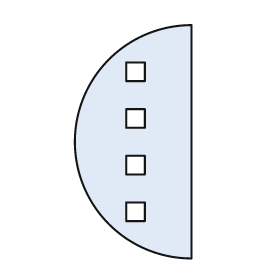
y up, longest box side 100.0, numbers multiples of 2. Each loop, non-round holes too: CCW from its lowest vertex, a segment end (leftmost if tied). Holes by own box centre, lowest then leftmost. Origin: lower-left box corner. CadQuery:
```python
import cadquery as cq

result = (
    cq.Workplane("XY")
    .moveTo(50.0, 0.0)
    .lineTo(50.0, 100.0)
    .threePointArc((0.0, 50.0), (50.0, 0.0))
    .close()
    .moveTo(22.0, 16.0)
    .lineTo(30.0, 16.0)
    .lineTo(30.0, 24.0)
    .lineTo(22.0, 24.0)
    .close()
    .moveTo(22.0, 36.0)
    .lineTo(30.0, 36.0)
    .lineTo(30.0, 44.0)
    .lineTo(22.0, 44.0)
    .close()
    .moveTo(22.0, 56.0)
    .lineTo(30.0, 56.0)
    .lineTo(30.0, 64.0)
    .lineTo(22.0, 64.0)
    .close()
    .moveTo(22.0, 76.0)
    .lineTo(30.0, 76.0)
    .lineTo(30.0, 84.0)
    .lineTo(22.0, 84.0)
    .close()
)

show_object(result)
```